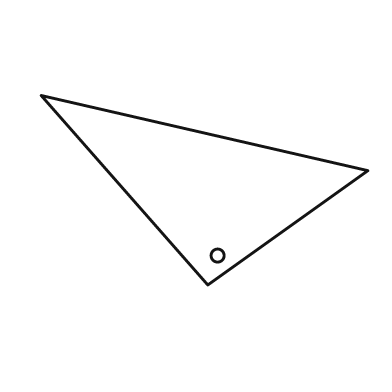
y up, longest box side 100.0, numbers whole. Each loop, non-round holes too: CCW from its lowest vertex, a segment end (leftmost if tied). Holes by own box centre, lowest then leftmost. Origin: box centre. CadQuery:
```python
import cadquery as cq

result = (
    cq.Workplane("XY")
    .moveTo(1.0, -29.0)
    .lineTo(50.0, 6.0)
    .lineTo(-50.0, 29.0)
    .close()
    .moveTo(4.0, -20.0)
    .circle(2.0)
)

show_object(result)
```